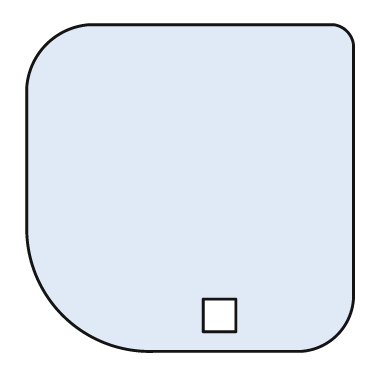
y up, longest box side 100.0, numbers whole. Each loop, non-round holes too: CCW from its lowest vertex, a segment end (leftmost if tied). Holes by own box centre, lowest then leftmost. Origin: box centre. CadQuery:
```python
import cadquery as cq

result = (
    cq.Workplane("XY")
    .moveTo(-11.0, -50.0)
    .lineTo(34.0, -50.0)
    .threePointArc((45.0, -45.0), (50.0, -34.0))
    .lineTo(50.0, 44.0)
    .threePointArc((48.0, 48.0), (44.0, 50.0))
    .lineTo(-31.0, 50.0)
    .threePointArc((-44.0, 44.0), (-50.0, 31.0))
    .lineTo(-50.0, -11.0)
    .threePointArc((-39.0, -39.0), (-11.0, -50.0))
    .close()
    .moveTo(4.0, -44.0)
    .lineTo(14.0, -44.0)
    .lineTo(14.0, -34.0)
    .lineTo(4.0, -34.0)
    .close()
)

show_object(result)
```